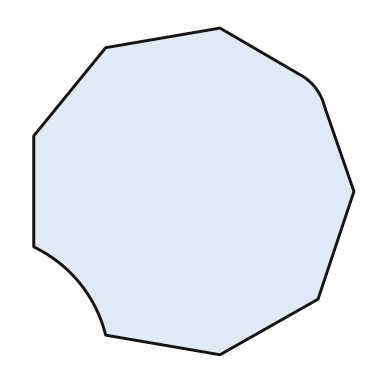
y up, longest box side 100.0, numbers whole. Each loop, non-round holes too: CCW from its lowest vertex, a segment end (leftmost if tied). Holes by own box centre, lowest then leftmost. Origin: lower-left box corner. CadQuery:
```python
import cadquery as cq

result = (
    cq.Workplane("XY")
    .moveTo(57.0, 0.0)
    .lineTo(87.0, 17.0)
    .lineTo(98.0, 50.0)
    .lineTo(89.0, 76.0)
    .threePointArc((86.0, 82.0), (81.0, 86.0))
    .lineTo(57.0, 100.0)
    .lineTo(22.0, 94.0)
    .lineTo(0.0, 67.0)
    .lineTo(0.0, 33.0)
    .threePointArc((14.0, 22.0), (22.0, 6.0))
    .close()
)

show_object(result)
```